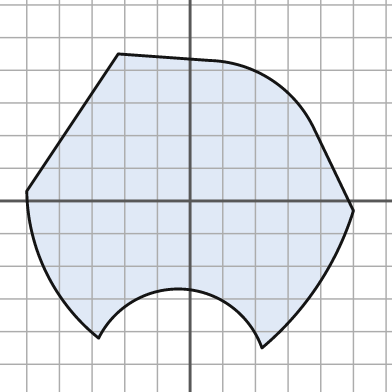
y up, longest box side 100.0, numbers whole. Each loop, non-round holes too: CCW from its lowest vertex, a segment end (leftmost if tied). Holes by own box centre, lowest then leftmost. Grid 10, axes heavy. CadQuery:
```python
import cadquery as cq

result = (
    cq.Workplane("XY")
    .moveTo(22.0, -45.0)
    .threePointArc((39.0, -26.0), (50.0, -3.0))
    .lineTo(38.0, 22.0)
    .threePointArc((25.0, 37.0), (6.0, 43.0))
    .lineTo(-22.0, 45.0)
    .lineTo(-50.0, 3.0)
    .threePointArc((-44.0, -22.0), (-28.0, -42.0))
    .threePointArc((-2.0, -27.0), (22.0, -45.0))
    .close()
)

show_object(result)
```